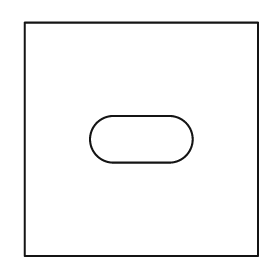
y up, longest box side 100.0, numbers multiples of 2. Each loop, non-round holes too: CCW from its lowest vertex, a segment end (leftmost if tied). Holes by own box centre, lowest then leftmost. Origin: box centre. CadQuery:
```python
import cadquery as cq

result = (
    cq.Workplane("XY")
    .moveTo(-50.0, -50.0)
    .lineTo(50.0, -50.0)
    .lineTo(50.0, 50.0)
    .lineTo(-50.0, 50.0)
    .close()
    .moveTo(-12.0, -10.0)
    .lineTo(12.0, -10.0)
    .threePointArc((22.0, 0.0), (12.0, 10.0))
    .lineTo(-12.0, 10.0)
    .threePointArc((-22.0, 0.0), (-12.0, -10.0))
    .close()
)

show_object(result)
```